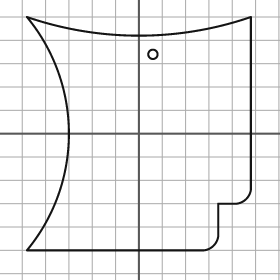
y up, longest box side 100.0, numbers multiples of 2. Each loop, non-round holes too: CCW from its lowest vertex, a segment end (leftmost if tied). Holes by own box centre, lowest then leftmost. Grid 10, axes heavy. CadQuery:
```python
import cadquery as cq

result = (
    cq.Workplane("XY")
    .moveTo(-48.0, -50.0)
    .lineTo(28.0, -50.0)
    .threePointArc((32.0, -48.0), (34.0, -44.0))
    .lineTo(34.0, -30.0)
    .lineTo(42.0, -30.0)
    .threePointArc((46.0, -28.0), (48.0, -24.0))
    .lineTo(48.0, 50.0)
    .threePointArc((0.0, 42.0), (-48.0, 50.0))
    .threePointArc((-30.0, 0.0), (-48.0, -50.0))
    .close()
    .moveTo(6.0, 34.0)
    .circle(2.0)
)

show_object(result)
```